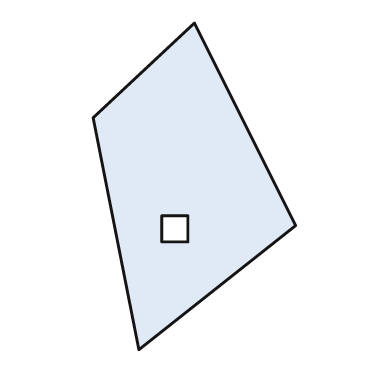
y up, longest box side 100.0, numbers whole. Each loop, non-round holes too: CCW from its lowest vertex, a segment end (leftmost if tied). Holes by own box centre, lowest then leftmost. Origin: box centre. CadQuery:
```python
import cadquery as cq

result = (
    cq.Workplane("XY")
    .moveTo(-17.0, -50.0)
    .lineTo(31.0, -12.0)
    .lineTo(0.0, 50.0)
    .lineTo(-31.0, 21.0)
    .close()
    .moveTo(-10.0, -17.0)
    .lineTo(-2.0, -17.0)
    .lineTo(-2.0, -9.0)
    .lineTo(-10.0, -9.0)
    .close()
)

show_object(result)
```